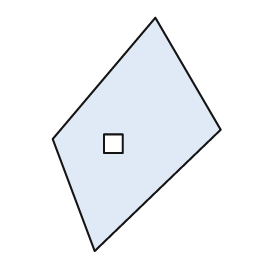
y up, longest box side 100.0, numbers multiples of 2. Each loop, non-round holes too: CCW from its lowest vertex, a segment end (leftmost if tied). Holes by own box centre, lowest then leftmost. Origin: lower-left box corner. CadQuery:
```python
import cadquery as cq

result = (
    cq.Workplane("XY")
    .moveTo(18.0, 0.0)
    .lineTo(72.0, 52.0)
    .lineTo(44.0, 100.0)
    .lineTo(0.0, 48.0)
    .close()
    .moveTo(22.0, 42.0)
    .lineTo(30.0, 42.0)
    .lineTo(30.0, 50.0)
    .lineTo(22.0, 50.0)
    .close()
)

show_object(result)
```